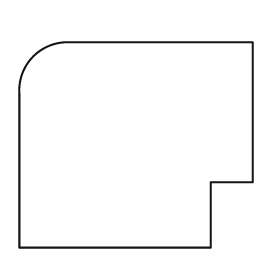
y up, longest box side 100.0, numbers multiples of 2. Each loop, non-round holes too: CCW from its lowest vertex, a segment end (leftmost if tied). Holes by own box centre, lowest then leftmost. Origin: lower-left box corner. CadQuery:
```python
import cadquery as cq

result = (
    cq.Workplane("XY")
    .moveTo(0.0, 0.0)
    .lineTo(82.0, 0.0)
    .lineTo(82.0, 28.0)
    .lineTo(100.0, 28.0)
    .lineTo(100.0, 88.0)
    .lineTo(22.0, 88.0)
    .threePointArc((6.0, 82.0), (0.0, 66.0))
    .close()
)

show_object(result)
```